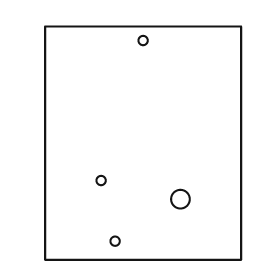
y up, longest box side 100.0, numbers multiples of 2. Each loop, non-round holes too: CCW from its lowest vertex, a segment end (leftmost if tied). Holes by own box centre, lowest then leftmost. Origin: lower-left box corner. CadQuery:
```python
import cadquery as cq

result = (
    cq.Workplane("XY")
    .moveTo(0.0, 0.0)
    .lineTo(84.0, 0.0)
    .lineTo(84.0, 100.0)
    .lineTo(0.0, 100.0)
    .close()
    .moveTo(30.0, 8.0)
    .circle(2.0)
    .moveTo(58.0, 26.0)
    .circle(4.0)
    .moveTo(24.0, 34.0)
    .circle(2.0)
    .moveTo(42.0, 94.0)
    .circle(2.0)
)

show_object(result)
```